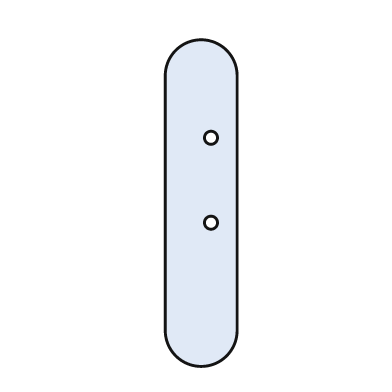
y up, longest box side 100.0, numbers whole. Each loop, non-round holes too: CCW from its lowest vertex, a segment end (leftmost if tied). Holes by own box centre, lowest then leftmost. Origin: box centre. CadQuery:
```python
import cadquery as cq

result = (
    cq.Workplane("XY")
    .moveTo(-11.0, -39.0)
    .threePointArc((0.0, -50.0), (11.0, -39.0))
    .lineTo(11.0, 39.0)
    .threePointArc((0.0, 50.0), (-11.0, 39.0))
    .close()
    .moveTo(3.0, -6.0)
    .circle(2.0)
    .moveTo(3.0, 20.0)
    .circle(2.0)
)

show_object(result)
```